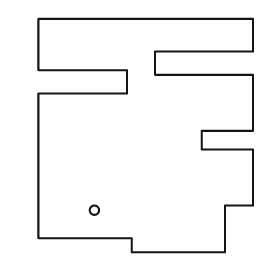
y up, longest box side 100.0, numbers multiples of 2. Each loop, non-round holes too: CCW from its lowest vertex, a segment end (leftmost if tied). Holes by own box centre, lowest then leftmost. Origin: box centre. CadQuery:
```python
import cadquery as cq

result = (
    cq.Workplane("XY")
    .moveTo(-6.0, -50.0)
    .lineTo(34.0, -50.0)
    .lineTo(34.0, -30.0)
    .lineTo(46.0, -30.0)
    .lineTo(46.0, -6.0)
    .lineTo(24.0, -6.0)
    .lineTo(24.0, 2.0)
    .lineTo(46.0, 2.0)
    .lineTo(46.0, 26.0)
    .lineTo(4.0, 26.0)
    .lineTo(4.0, 36.0)
    .lineTo(46.0, 36.0)
    .lineTo(46.0, 50.0)
    .lineTo(-46.0, 50.0)
    .lineTo(-46.0, 28.0)
    .lineTo(-8.0, 28.0)
    .lineTo(-8.0, 18.0)
    .lineTo(-46.0, 18.0)
    .lineTo(-46.0, -44.0)
    .lineTo(-6.0, -44.0)
    .close()
    .moveTo(-22.0, -32.0)
    .circle(2.0)
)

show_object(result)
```